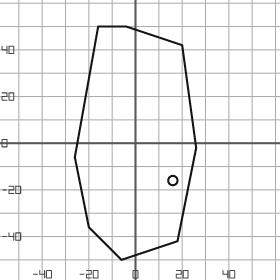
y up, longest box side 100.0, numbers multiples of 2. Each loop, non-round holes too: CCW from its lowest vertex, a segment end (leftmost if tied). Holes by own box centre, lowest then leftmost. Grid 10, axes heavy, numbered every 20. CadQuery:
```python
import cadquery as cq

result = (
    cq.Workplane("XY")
    .moveTo(-6.0, -50.0)
    .lineTo(18.0, -42.0)
    .lineTo(26.0, -2.0)
    .lineTo(20.0, 42.0)
    .lineTo(-4.0, 50.0)
    .lineTo(-16.0, 50.0)
    .lineTo(-26.0, -6.0)
    .lineTo(-20.0, -36.0)
    .close()
    .moveTo(16.0, -16.0)
    .circle(2.0)
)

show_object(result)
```